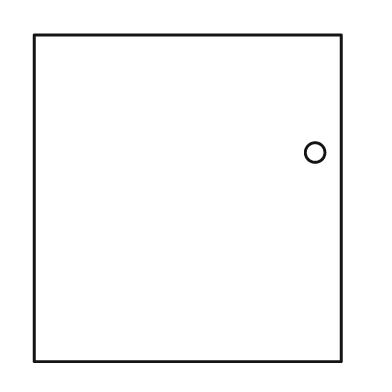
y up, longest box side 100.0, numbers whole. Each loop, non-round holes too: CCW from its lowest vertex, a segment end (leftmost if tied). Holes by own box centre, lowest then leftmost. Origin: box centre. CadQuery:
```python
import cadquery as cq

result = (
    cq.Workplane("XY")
    .moveTo(-47.0, -50.0)
    .lineTo(47.0, -50.0)
    .lineTo(47.0, 50.0)
    .lineTo(-47.0, 50.0)
    .close()
    .moveTo(39.0, 14.0)
    .circle(3.0)
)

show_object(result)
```